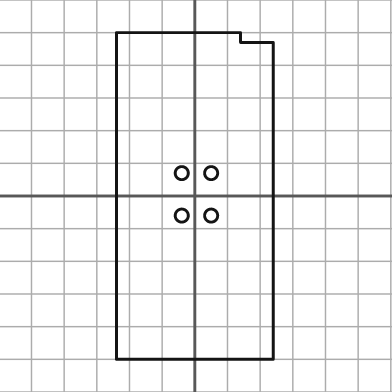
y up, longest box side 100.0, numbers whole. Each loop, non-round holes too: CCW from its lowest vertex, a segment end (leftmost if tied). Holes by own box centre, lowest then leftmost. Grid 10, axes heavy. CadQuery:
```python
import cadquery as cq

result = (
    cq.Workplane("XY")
    .moveTo(-24.0, -50.0)
    .lineTo(24.0, -50.0)
    .lineTo(24.0, 47.0)
    .lineTo(14.0, 47.0)
    .lineTo(14.0, 50.0)
    .lineTo(-24.0, 50.0)
    .close()
    .moveTo(-4.0, -6.0)
    .circle(2.0)
    .moveTo(5.0, -6.0)
    .circle(2.0)
    .moveTo(-4.0, 7.0)
    .circle(2.0)
    .moveTo(5.0, 7.0)
    .circle(2.0)
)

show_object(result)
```